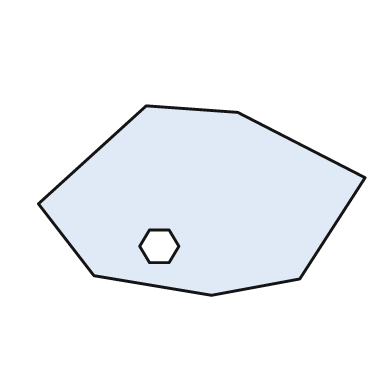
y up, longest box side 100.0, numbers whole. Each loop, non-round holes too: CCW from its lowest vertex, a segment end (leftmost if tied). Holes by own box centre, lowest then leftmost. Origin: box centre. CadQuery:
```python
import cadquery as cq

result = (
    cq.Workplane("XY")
    .moveTo(3.0, -29.0)
    .lineTo(30.0, -24.0)
    .lineTo(50.0, 7.0)
    .lineTo(11.0, 27.0)
    .lineTo(-17.0, 29.0)
    .lineTo(-50.0, -1.0)
    .lineTo(-33.0, -23.0)
    .close()
    .moveTo(-16.0, -19.0)
    .lineTo(-10.0, -19.0)
    .lineTo(-7.0, -14.0)
    .lineTo(-10.0, -9.0)
    .lineTo(-16.0, -9.0)
    .lineTo(-19.0, -14.0)
    .close()
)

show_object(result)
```